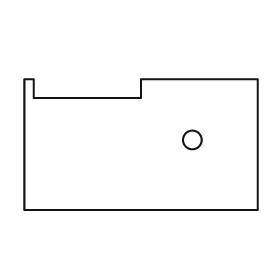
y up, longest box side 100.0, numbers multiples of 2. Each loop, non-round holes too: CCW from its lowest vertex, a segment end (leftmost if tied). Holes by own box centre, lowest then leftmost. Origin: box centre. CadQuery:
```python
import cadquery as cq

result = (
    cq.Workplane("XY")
    .moveTo(-50.0, -28.0)
    .lineTo(50.0, -28.0)
    .lineTo(50.0, 28.0)
    .lineTo(0.0, 28.0)
    .lineTo(0.0, 20.0)
    .lineTo(-46.0, 20.0)
    .lineTo(-46.0, 28.0)
    .lineTo(-50.0, 28.0)
    .close()
    .moveTo(22.0, 2.0)
    .circle(4.0)
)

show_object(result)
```